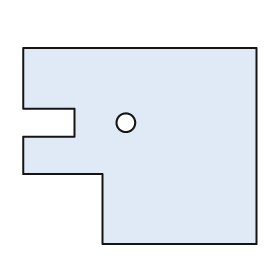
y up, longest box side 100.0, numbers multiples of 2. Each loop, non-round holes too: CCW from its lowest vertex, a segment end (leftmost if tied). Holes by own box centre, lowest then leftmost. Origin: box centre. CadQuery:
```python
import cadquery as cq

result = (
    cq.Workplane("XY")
    .moveTo(-16.0, -42.0)
    .lineTo(50.0, -42.0)
    .lineTo(50.0, 42.0)
    .lineTo(-50.0, 42.0)
    .lineTo(-50.0, 16.0)
    .lineTo(-28.0, 16.0)
    .lineTo(-28.0, 4.0)
    .lineTo(-50.0, 4.0)
    .lineTo(-50.0, -12.0)
    .lineTo(-16.0, -12.0)
    .close()
    .moveTo(-6.0, 10.0)
    .circle(4.0)
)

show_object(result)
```